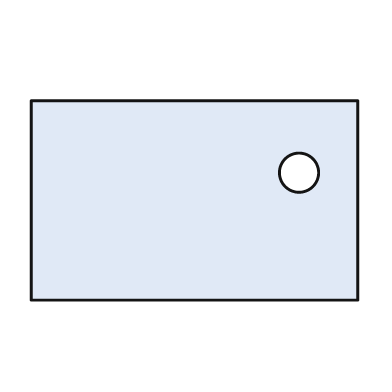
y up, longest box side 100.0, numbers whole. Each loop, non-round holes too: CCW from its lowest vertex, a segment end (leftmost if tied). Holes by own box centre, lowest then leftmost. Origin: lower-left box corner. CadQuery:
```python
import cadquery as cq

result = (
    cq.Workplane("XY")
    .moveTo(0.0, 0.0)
    .lineTo(100.0, 0.0)
    .lineTo(100.0, 61.0)
    .lineTo(0.0, 61.0)
    .close()
    .moveTo(82.0, 39.0)
    .circle(6.0)
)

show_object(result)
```